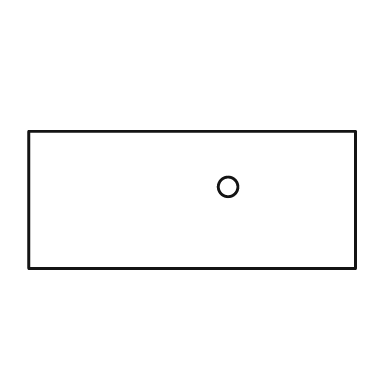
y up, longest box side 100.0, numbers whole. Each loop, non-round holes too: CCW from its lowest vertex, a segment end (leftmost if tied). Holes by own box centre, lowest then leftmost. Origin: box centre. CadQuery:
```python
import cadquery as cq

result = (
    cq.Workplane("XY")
    .moveTo(-50.0, -21.0)
    .lineTo(50.0, -21.0)
    .lineTo(50.0, 21.0)
    .lineTo(-50.0, 21.0)
    .close()
    .moveTo(11.0, 4.0)
    .circle(3.0)
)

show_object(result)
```